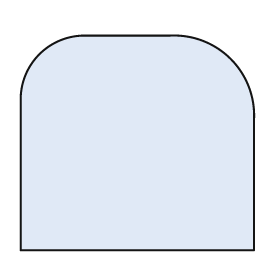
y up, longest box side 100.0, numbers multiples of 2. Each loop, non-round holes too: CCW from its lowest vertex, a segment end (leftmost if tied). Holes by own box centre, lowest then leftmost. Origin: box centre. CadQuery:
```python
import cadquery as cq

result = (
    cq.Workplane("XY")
    .moveTo(-50.0, -46.0)
    .lineTo(50.0, -46.0)
    .lineTo(50.0, 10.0)
    .threePointArc((40.0, 36.0), (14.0, 46.0))
    .lineTo(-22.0, 46.0)
    .threePointArc((-42.0, 38.0), (-50.0, 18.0))
    .close()
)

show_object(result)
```